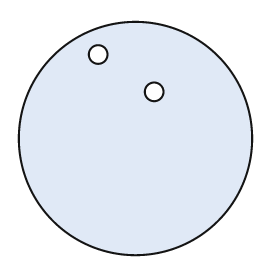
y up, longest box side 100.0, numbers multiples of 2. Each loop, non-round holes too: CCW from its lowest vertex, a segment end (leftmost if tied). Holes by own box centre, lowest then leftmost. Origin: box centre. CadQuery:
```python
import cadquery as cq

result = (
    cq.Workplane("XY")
    .moveTo(0.0, 0.0)
    .circle(50.0)
    .moveTo(8.0, 20.0)
    .circle(4.0)
    .moveTo(-16.0, 36.0)
    .circle(4.0)
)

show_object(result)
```